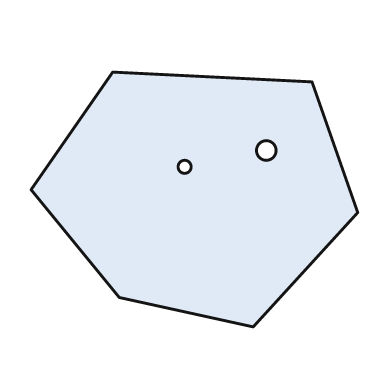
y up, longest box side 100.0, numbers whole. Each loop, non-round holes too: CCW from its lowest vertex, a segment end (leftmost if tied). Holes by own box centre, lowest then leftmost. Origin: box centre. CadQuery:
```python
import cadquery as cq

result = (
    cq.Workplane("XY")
    .moveTo(18.0, -39.0)
    .lineTo(50.0, -4.0)
    .lineTo(36.0, 36.0)
    .lineTo(-25.0, 39.0)
    .lineTo(-50.0, 3.0)
    .lineTo(-23.0, -30.0)
    .close()
    .moveTo(-3.0, 10.0)
    .circle(2.0)
    .moveTo(22.0, 15.0)
    .circle(3.0)
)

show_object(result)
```